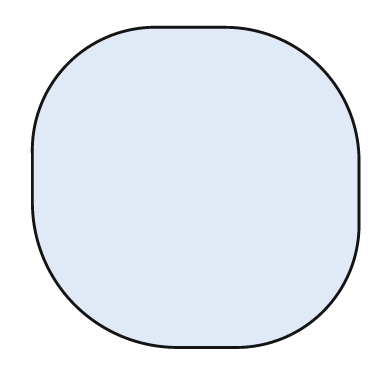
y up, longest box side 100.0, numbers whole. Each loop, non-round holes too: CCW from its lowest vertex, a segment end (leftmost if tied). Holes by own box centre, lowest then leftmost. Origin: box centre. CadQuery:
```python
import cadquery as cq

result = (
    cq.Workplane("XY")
    .moveTo(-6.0, -49.0)
    .lineTo(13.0, -49.0)
    .threePointArc((39.0, -38.0), (50.0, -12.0))
    .lineTo(50.0, 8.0)
    .threePointArc((38.0, 37.0), (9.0, 49.0))
    .lineTo(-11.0, 49.0)
    .threePointArc((-39.0, 38.0), (-50.0, 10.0))
    .lineTo(-50.0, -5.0)
    .threePointArc((-37.0, -36.0), (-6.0, -49.0))
    .close()
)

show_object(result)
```